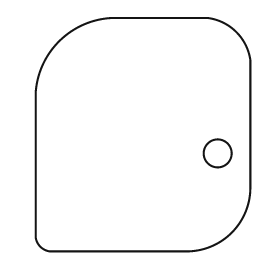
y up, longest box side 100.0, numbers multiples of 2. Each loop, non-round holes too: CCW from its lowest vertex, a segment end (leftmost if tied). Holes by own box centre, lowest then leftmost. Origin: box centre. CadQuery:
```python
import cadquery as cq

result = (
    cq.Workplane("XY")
    .moveTo(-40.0, -50.0)
    .lineTo(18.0, -50.0)
    .threePointArc((38.0, -42.0), (46.0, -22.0))
    .lineTo(46.0, 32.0)
    .threePointArc((40.0, 44.0), (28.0, 50.0))
    .lineTo(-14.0, 50.0)
    .threePointArc((-36.0, 40.0), (-46.0, 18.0))
    .lineTo(-46.0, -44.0)
    .threePointArc((-44.0, -48.0), (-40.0, -50.0))
    .close()
    .moveTo(32.0, -8.0)
    .circle(6.0)
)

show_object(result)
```